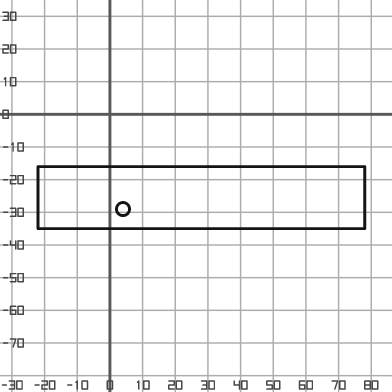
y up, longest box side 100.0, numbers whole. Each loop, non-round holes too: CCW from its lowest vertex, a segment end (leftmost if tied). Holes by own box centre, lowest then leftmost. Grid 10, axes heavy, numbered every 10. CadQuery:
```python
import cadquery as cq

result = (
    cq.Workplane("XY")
    .moveTo(-22.0, -35.0)
    .lineTo(78.0, -35.0)
    .lineTo(78.0, -16.0)
    .lineTo(-22.0, -16.0)
    .close()
    .moveTo(4.0, -29.0)
    .circle(2.0)
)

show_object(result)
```